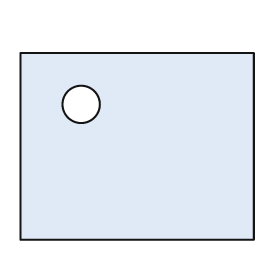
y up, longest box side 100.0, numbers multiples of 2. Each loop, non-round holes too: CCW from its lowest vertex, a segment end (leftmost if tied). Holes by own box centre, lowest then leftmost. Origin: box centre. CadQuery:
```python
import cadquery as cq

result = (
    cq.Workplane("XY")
    .moveTo(-50.0, -40.0)
    .lineTo(50.0, -40.0)
    .lineTo(50.0, 40.0)
    .lineTo(-50.0, 40.0)
    .close()
    .moveTo(-24.0, 18.0)
    .circle(8.0)
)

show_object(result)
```